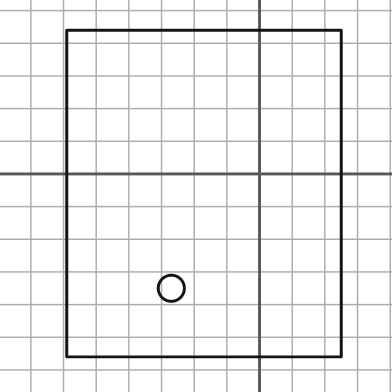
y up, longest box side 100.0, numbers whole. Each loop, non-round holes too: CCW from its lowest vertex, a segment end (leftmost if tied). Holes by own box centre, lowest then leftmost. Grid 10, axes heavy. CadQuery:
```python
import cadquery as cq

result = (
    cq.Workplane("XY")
    .moveTo(-59.0, -56.0)
    .lineTo(25.0, -56.0)
    .lineTo(25.0, 44.0)
    .lineTo(-59.0, 44.0)
    .close()
    .moveTo(-27.0, -35.0)
    .circle(4.0)
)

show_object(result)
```